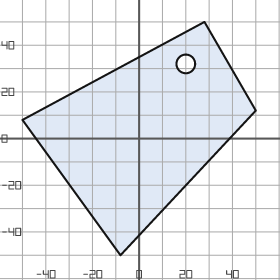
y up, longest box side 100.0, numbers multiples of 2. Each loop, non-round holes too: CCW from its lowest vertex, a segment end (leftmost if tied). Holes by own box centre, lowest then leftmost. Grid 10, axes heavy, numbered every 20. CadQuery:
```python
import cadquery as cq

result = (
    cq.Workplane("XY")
    .moveTo(-8.0, -50.0)
    .lineTo(50.0, 12.0)
    .lineTo(28.0, 50.0)
    .lineTo(-50.0, 8.0)
    .close()
    .moveTo(20.0, 32.0)
    .circle(4.0)
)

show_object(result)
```